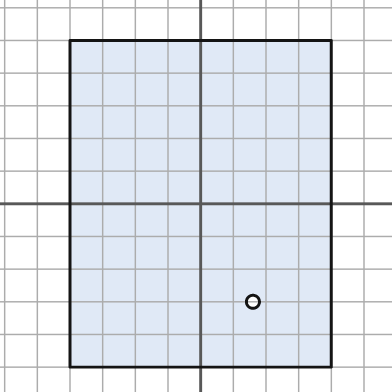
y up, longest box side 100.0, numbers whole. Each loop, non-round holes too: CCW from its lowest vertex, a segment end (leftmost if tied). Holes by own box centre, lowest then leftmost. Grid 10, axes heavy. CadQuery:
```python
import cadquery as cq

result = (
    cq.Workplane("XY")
    .moveTo(-40.0, -50.0)
    .lineTo(40.0, -50.0)
    .lineTo(40.0, 50.0)
    .lineTo(-40.0, 50.0)
    .close()
    .moveTo(16.0, -30.0)
    .circle(2.0)
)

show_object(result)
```